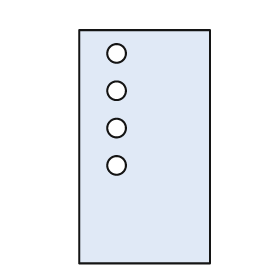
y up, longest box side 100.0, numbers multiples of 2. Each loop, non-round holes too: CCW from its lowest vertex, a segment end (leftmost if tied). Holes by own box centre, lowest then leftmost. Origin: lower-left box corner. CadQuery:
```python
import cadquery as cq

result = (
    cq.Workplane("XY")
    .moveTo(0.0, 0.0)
    .lineTo(56.0, 0.0)
    .lineTo(56.0, 100.0)
    .lineTo(0.0, 100.0)
    .close()
    .moveTo(16.0, 42.0)
    .circle(4.0)
    .moveTo(16.0, 58.0)
    .circle(4.0)
    .moveTo(16.0, 74.0)
    .circle(4.0)
    .moveTo(16.0, 90.0)
    .circle(4.0)
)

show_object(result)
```